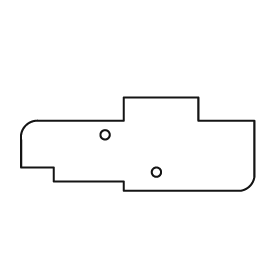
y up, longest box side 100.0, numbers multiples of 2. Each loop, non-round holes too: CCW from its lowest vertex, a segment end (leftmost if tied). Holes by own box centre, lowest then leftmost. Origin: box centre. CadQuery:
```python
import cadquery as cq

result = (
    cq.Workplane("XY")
    .moveTo(-6.0, -20.0)
    .lineTo(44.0, -20.0)
    .threePointArc((48.0, -18.0), (50.0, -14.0))
    .lineTo(50.0, 10.0)
    .lineTo(26.0, 10.0)
    .lineTo(26.0, 20.0)
    .lineTo(-6.0, 20.0)
    .lineTo(-6.0, 10.0)
    .lineTo(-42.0, 10.0)
    .threePointArc((-48.0, 8.0), (-50.0, 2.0))
    .lineTo(-50.0, -10.0)
    .lineTo(-36.0, -10.0)
    .lineTo(-36.0, -16.0)
    .lineTo(-6.0, -16.0)
    .close()
    .moveTo(8.0, -12.0)
    .circle(2.0)
    .moveTo(-14.0, 4.0)
    .circle(2.0)
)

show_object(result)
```